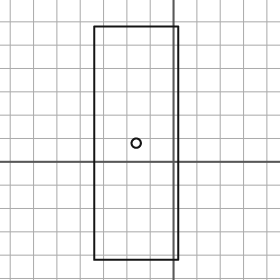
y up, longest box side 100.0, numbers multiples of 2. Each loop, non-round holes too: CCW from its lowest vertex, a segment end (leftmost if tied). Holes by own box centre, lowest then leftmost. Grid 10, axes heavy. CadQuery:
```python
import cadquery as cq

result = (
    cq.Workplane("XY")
    .moveTo(-34.0, -42.0)
    .lineTo(2.0, -42.0)
    .lineTo(2.0, 58.0)
    .lineTo(-34.0, 58.0)
    .close()
    .moveTo(-16.0, 8.0)
    .circle(2.0)
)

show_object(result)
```